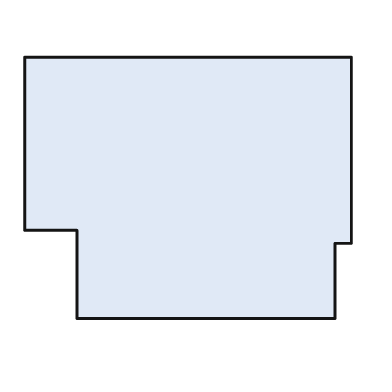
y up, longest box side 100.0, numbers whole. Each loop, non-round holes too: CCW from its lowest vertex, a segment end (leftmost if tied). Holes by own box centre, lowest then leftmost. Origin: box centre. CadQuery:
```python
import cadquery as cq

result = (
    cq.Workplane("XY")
    .moveTo(-34.0, -40.0)
    .lineTo(45.0, -40.0)
    .lineTo(45.0, -17.0)
    .lineTo(50.0, -17.0)
    .lineTo(50.0, 40.0)
    .lineTo(-50.0, 40.0)
    .lineTo(-50.0, -13.0)
    .lineTo(-34.0, -13.0)
    .close()
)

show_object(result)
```